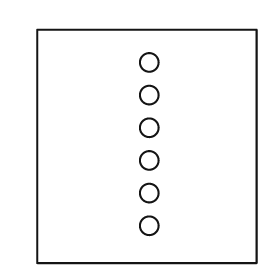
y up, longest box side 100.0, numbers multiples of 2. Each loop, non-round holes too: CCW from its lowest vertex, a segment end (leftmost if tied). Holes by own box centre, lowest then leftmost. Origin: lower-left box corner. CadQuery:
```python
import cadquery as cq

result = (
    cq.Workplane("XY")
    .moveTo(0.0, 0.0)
    .lineTo(94.0, 0.0)
    .lineTo(94.0, 100.0)
    .lineTo(0.0, 100.0)
    .close()
    .moveTo(48.0, 16.0)
    .circle(4.0)
    .moveTo(48.0, 30.0)
    .circle(4.0)
    .moveTo(48.0, 44.0)
    .circle(4.0)
    .moveTo(48.0, 58.0)
    .circle(4.0)
    .moveTo(48.0, 72.0)
    .circle(4.0)
    .moveTo(48.0, 86.0)
    .circle(4.0)
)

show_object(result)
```